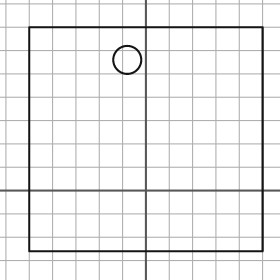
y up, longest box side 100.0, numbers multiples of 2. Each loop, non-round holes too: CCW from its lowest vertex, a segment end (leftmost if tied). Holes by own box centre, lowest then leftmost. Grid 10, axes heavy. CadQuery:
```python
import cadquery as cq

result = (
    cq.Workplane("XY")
    .moveTo(-50.0, -26.0)
    .lineTo(50.0, -26.0)
    .lineTo(50.0, 70.0)
    .lineTo(-50.0, 70.0)
    .close()
    .moveTo(-8.0, 56.0)
    .circle(6.0)
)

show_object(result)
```